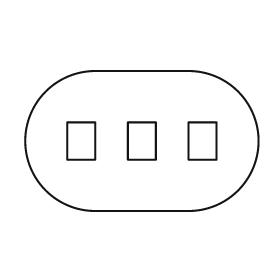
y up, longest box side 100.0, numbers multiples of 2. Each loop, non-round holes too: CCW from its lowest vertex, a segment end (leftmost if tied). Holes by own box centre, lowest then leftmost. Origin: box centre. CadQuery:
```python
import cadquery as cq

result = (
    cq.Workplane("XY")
    .moveTo(-20.0, -30.0)
    .lineTo(20.0, -30.0)
    .threePointArc((50.0, 0.0), (20.0, 30.0))
    .lineTo(-20.0, 30.0)
    .threePointArc((-50.0, 0.0), (-20.0, -30.0))
    .close()
    .moveTo(-32.0, -8.0)
    .lineTo(-20.0, -8.0)
    .lineTo(-20.0, 8.0)
    .lineTo(-32.0, 8.0)
    .close()
    .moveTo(-6.0, -8.0)
    .lineTo(6.0, -8.0)
    .lineTo(6.0, 8.0)
    .lineTo(-6.0, 8.0)
    .close()
    .moveTo(20.0, -8.0)
    .lineTo(32.0, -8.0)
    .lineTo(32.0, 8.0)
    .lineTo(20.0, 8.0)
    .close()
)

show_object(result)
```